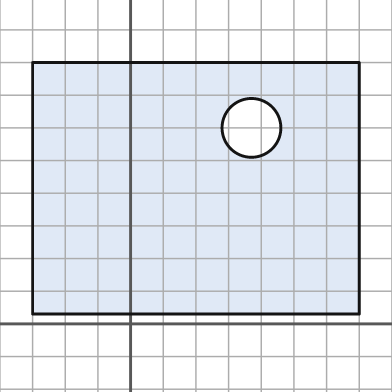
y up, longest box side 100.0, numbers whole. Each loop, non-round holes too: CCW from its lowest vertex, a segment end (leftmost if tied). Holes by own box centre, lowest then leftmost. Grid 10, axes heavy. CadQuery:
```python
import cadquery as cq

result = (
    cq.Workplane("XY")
    .moveTo(-30.0, 3.0)
    .lineTo(70.0, 3.0)
    .lineTo(70.0, 80.0)
    .lineTo(-30.0, 80.0)
    .close()
    .moveTo(37.0, 60.0)
    .circle(9.0)
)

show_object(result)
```